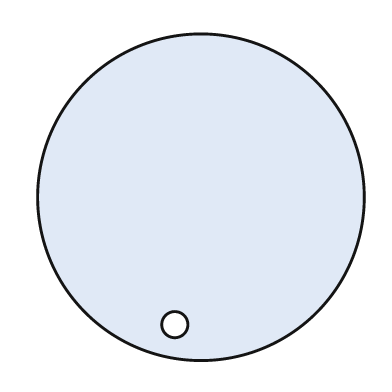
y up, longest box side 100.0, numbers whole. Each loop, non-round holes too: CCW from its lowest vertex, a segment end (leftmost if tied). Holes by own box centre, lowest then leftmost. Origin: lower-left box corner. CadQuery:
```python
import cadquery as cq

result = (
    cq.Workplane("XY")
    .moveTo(50.0, 50.0)
    .circle(50.0)
    .moveTo(42.0, 11.0)
    .circle(4.0)
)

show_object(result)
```